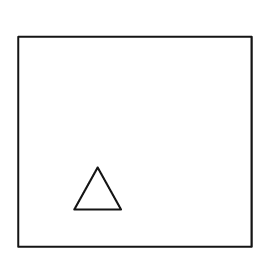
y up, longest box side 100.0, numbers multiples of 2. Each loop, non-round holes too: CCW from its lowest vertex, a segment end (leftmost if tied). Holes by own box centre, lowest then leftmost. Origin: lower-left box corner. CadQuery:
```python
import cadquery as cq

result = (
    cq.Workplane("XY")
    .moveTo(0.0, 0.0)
    .lineTo(100.0, 0.0)
    .lineTo(100.0, 90.0)
    .lineTo(0.0, 90.0)
    .close()
    .moveTo(24.0, 16.0)
    .lineTo(44.0, 16.0)
    .lineTo(34.0, 34.0)
    .close()
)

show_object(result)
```